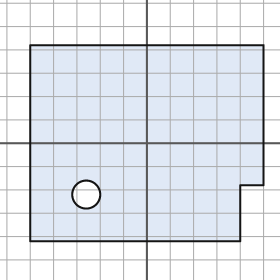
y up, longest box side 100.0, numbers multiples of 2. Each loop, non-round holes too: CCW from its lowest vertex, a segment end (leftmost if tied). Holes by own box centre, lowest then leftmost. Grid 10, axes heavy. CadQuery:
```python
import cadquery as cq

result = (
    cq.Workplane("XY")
    .moveTo(-50.0, -42.0)
    .lineTo(40.0, -42.0)
    .lineTo(40.0, -18.0)
    .lineTo(50.0, -18.0)
    .lineTo(50.0, 42.0)
    .lineTo(-50.0, 42.0)
    .close()
    .moveTo(-26.0, -22.0)
    .circle(6.0)
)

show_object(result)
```